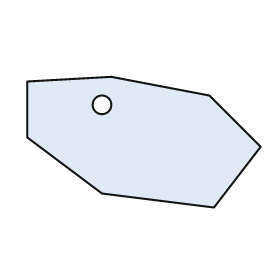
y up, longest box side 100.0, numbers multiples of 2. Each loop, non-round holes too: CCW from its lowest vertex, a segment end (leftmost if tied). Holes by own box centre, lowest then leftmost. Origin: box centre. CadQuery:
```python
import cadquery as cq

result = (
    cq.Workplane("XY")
    .moveTo(30.0, -28.0)
    .lineTo(50.0, -2.0)
    .lineTo(28.0, 20.0)
    .lineTo(-14.0, 28.0)
    .lineTo(-50.0, 26.0)
    .lineTo(-50.0, 2.0)
    .lineTo(-18.0, -22.0)
    .close()
    .moveTo(-18.0, 16.0)
    .circle(4.0)
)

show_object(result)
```